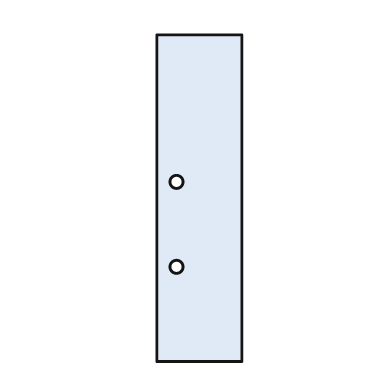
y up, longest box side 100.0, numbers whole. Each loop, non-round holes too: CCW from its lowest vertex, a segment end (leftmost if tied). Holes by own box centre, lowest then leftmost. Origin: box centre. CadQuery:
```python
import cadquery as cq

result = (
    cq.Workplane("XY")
    .moveTo(-13.0, -50.0)
    .lineTo(13.0, -50.0)
    .lineTo(13.0, 50.0)
    .lineTo(-13.0, 50.0)
    .close()
    .moveTo(-7.0, -21.0)
    .circle(2.0)
    .moveTo(-7.0, 5.0)
    .circle(2.0)
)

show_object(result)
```